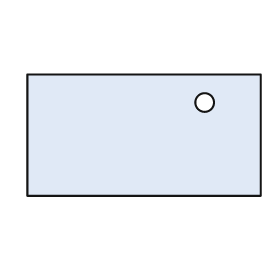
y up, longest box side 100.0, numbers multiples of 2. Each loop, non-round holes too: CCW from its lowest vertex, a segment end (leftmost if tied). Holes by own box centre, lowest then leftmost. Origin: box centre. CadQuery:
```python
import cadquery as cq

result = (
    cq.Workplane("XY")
    .moveTo(-50.0, -26.0)
    .lineTo(50.0, -26.0)
    .lineTo(50.0, 26.0)
    .lineTo(-50.0, 26.0)
    .close()
    .moveTo(26.0, 14.0)
    .circle(4.0)
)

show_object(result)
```